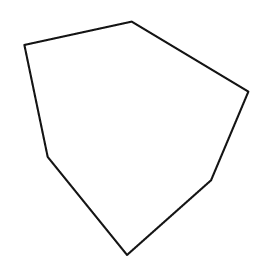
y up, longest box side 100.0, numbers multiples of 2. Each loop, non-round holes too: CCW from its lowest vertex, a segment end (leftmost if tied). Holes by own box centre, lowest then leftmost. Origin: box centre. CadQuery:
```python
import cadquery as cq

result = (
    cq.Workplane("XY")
    .moveTo(-4.0, -50.0)
    .lineTo(32.0, -18.0)
    .lineTo(48.0, 20.0)
    .lineTo(-2.0, 50.0)
    .lineTo(-48.0, 40.0)
    .lineTo(-38.0, -8.0)
    .close()
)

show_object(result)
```